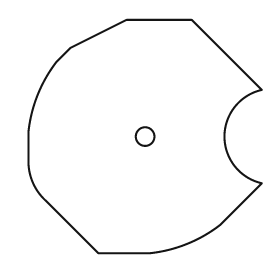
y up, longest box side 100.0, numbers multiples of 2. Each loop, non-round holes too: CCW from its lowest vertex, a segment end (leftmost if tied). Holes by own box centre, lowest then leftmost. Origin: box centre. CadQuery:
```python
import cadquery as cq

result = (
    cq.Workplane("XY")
    .moveTo(-20.0, -50.0)
    .lineTo(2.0, -50.0)
    .threePointArc((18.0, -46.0), (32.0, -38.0))
    .lineTo(50.0, -20.0)
    .threePointArc((34.0, 0.0), (50.0, 20.0))
    .lineTo(20.0, 50.0)
    .lineTo(-8.0, 50.0)
    .lineTo(-32.0, 38.0)
    .lineTo(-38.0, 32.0)
    .threePointArc((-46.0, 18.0), (-50.0, 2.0))
    .lineTo(-50.0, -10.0)
    .threePointArc((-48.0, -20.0), (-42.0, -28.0))
    .close()
    .moveTo(0.0, 0.0)
    .circle(4.0)
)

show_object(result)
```